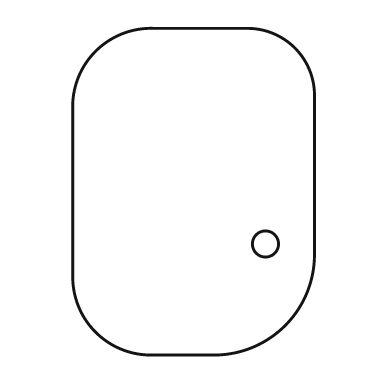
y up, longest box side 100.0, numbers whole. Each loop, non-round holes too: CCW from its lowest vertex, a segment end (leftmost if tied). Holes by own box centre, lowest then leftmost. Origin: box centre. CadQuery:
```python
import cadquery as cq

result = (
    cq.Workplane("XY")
    .moveTo(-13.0, -50.0)
    .lineTo(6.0, -50.0)
    .threePointArc((28.0, -41.0), (37.0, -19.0))
    .lineTo(37.0, 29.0)
    .threePointArc((31.0, 44.0), (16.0, 50.0))
    .lineTo(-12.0, 50.0)
    .threePointArc((-30.0, 43.0), (-37.0, 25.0))
    .lineTo(-37.0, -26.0)
    .threePointArc((-30.0, -43.0), (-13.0, -50.0))
    .close()
    .moveTo(22.0, -16.0)
    .circle(4.0)
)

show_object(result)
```